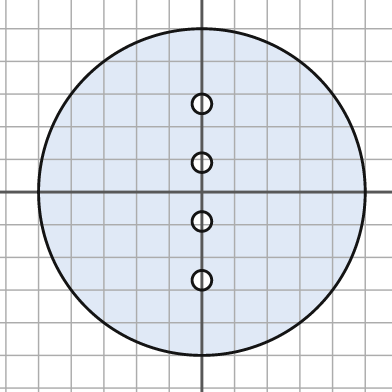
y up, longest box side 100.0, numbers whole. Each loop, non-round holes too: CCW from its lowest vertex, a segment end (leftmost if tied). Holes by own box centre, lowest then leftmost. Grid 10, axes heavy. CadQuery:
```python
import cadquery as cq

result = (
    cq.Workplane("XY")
    .moveTo(0.0, 0.0)
    .circle(50.0)
    .moveTo(0.0, -27.0)
    .circle(3.0)
    .moveTo(0.0, -9.0)
    .circle(3.0)
    .moveTo(0.0, 9.0)
    .circle(3.0)
    .moveTo(0.0, 27.0)
    .circle(3.0)
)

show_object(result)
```